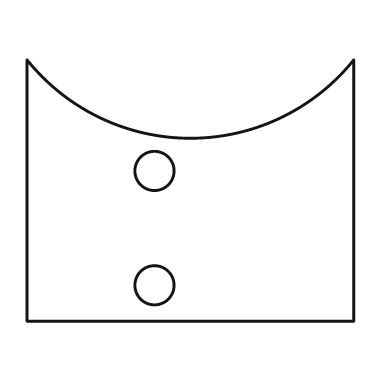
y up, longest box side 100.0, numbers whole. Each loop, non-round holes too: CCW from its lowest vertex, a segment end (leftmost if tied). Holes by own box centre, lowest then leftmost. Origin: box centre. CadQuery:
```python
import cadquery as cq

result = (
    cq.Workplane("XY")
    .moveTo(-50.0, -40.0)
    .lineTo(50.0, -40.0)
    .lineTo(50.0, 40.0)
    .threePointArc((0.0, 16.0), (-50.0, 40.0))
    .close()
    .moveTo(-11.0, -29.0)
    .circle(6.0)
    .moveTo(-11.0, 6.0)
    .circle(6.0)
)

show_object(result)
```